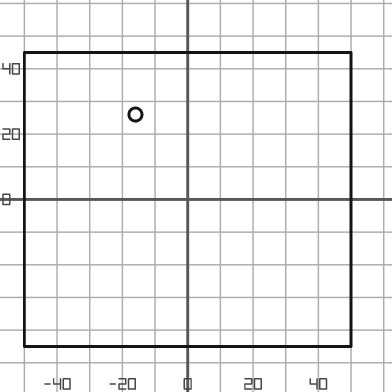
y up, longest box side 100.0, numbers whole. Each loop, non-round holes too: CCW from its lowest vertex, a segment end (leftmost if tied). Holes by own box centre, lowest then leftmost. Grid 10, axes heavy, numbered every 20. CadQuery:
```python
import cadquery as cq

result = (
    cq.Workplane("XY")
    .moveTo(-50.0, -45.0)
    .lineTo(50.0, -45.0)
    .lineTo(50.0, 45.0)
    .lineTo(-50.0, 45.0)
    .close()
    .moveTo(-16.0, 26.0)
    .circle(2.0)
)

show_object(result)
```